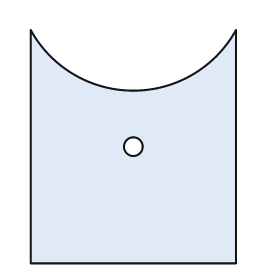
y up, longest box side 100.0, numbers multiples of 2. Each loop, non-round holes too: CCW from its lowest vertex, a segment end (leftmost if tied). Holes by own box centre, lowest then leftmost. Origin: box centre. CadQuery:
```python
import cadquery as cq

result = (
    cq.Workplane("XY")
    .moveTo(-44.0, -50.0)
    .lineTo(44.0, -50.0)
    .lineTo(44.0, 50.0)
    .threePointArc((0.0, 24.0), (-44.0, 50.0))
    .close()
    .moveTo(0.0, 0.0)
    .circle(4.0)
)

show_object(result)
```